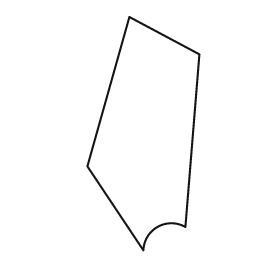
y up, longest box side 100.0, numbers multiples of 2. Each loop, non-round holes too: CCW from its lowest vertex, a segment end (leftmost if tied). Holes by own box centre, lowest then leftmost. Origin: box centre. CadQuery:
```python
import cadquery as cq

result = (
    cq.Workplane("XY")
    .moveTo(0.0, -50.0)
    .threePointArc((6.0, -40.0), (18.0, -40.0))
    .lineTo(24.0, 34.0)
    .lineTo(-6.0, 50.0)
    .lineTo(-24.0, -14.0)
    .close()
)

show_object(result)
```